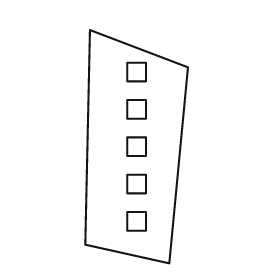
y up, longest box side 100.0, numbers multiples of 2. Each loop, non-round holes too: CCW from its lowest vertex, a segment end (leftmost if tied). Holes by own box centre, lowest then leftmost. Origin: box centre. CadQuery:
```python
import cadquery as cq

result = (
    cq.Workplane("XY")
    .moveTo(14.0, -50.0)
    .lineTo(22.0, 34.0)
    .lineTo(-20.0, 50.0)
    .lineTo(-22.0, -42.0)
    .close()
    .moveTo(-4.0, -36.0)
    .lineTo(4.0, -36.0)
    .lineTo(4.0, -28.0)
    .lineTo(-4.0, -28.0)
    .close()
    .moveTo(-4.0, -20.0)
    .lineTo(4.0, -20.0)
    .lineTo(4.0, -12.0)
    .lineTo(-4.0, -12.0)
    .close()
    .moveTo(-4.0, -4.0)
    .lineTo(4.0, -4.0)
    .lineTo(4.0, 4.0)
    .lineTo(-4.0, 4.0)
    .close()
    .moveTo(-4.0, 12.0)
    .lineTo(4.0, 12.0)
    .lineTo(4.0, 20.0)
    .lineTo(-4.0, 20.0)
    .close()
    .moveTo(-4.0, 28.0)
    .lineTo(4.0, 28.0)
    .lineTo(4.0, 36.0)
    .lineTo(-4.0, 36.0)
    .close()
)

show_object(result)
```